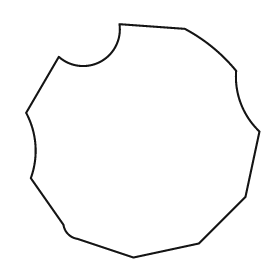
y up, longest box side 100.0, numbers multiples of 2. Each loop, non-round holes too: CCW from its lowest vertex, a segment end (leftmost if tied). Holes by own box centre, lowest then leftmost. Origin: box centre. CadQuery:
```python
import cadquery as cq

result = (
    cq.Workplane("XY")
    .moveTo(-4.0, -50.0)
    .lineTo(24.0, -44.0)
    .lineTo(44.0, -24.0)
    .lineTo(50.0, 4.0)
    .threePointArc((42.0, 16.0), (40.0, 30.0))
    .threePointArc((30.0, 40.0), (18.0, 48.0))
    .lineTo(-10.0, 50.0)
    .threePointArc((-18.0, 34.0), (-36.0, 36.0))
    .lineTo(-50.0, 12.0)
    .threePointArc((-46.0, -2.0), (-48.0, -16.0))
    .lineTo(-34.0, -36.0)
    .threePointArc((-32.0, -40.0), (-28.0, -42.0))
    .close()
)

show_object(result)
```